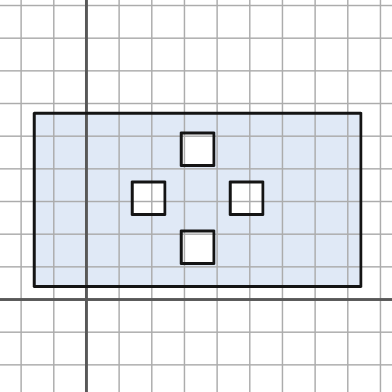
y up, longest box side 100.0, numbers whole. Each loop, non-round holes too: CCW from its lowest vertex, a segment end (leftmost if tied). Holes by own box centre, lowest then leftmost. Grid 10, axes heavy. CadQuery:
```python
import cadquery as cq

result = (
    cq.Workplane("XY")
    .moveTo(-16.0, 4.0)
    .lineTo(84.0, 4.0)
    .lineTo(84.0, 57.0)
    .lineTo(-16.0, 57.0)
    .close()
    .moveTo(29.0, 11.0)
    .lineTo(39.0, 11.0)
    .lineTo(39.0, 21.0)
    .lineTo(29.0, 21.0)
    .close()
    .moveTo(14.0, 26.0)
    .lineTo(24.0, 26.0)
    .lineTo(24.0, 36.0)
    .lineTo(14.0, 36.0)
    .close()
    .moveTo(44.0, 26.0)
    .lineTo(54.0, 26.0)
    .lineTo(54.0, 36.0)
    .lineTo(44.0, 36.0)
    .close()
    .moveTo(29.0, 41.0)
    .lineTo(39.0, 41.0)
    .lineTo(39.0, 51.0)
    .lineTo(29.0, 51.0)
    .close()
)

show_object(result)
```